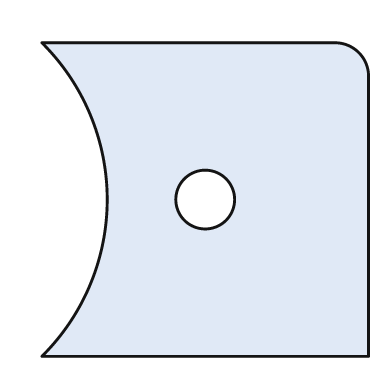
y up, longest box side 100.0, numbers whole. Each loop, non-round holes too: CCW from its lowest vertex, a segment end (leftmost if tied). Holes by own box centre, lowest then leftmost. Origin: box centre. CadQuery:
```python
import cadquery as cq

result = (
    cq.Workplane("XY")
    .moveTo(-50.0, -48.0)
    .lineTo(50.0, -48.0)
    .lineTo(50.0, 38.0)
    .threePointArc((47.0, 45.0), (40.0, 48.0))
    .lineTo(-50.0, 48.0)
    .threePointArc((-30.0, 0.0), (-50.0, -48.0))
    .close()
    .moveTo(0.0, 0.0)
    .circle(9.0)
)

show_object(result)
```